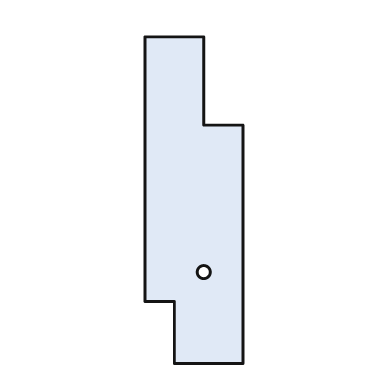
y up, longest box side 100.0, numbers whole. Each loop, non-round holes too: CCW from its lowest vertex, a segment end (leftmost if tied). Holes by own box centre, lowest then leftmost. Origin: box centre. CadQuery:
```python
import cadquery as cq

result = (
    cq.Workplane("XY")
    .moveTo(-6.0, -50.0)
    .lineTo(15.0, -50.0)
    .lineTo(15.0, 23.0)
    .lineTo(3.0, 23.0)
    .lineTo(3.0, 50.0)
    .lineTo(-15.0, 50.0)
    .lineTo(-15.0, -31.0)
    .lineTo(-6.0, -31.0)
    .close()
    .moveTo(3.0, -22.0)
    .circle(2.0)
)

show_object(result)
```